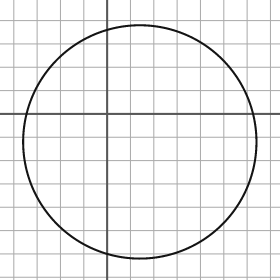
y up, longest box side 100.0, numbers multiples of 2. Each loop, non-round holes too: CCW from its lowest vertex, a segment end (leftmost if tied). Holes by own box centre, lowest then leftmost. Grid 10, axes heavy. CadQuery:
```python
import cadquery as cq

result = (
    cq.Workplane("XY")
    .moveTo(14.0, -12.0)
    .circle(50.0)
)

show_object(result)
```